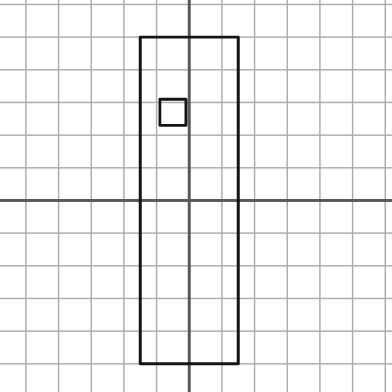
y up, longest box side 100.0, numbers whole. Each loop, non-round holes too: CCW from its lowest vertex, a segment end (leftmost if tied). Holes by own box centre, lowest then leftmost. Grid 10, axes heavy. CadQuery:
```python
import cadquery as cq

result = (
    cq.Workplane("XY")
    .moveTo(-15.0, -50.0)
    .lineTo(15.0, -50.0)
    .lineTo(15.0, 50.0)
    .lineTo(-15.0, 50.0)
    .close()
    .moveTo(-9.0, 23.0)
    .lineTo(-1.0, 23.0)
    .lineTo(-1.0, 31.0)
    .lineTo(-9.0, 31.0)
    .close()
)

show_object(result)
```